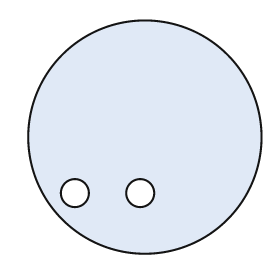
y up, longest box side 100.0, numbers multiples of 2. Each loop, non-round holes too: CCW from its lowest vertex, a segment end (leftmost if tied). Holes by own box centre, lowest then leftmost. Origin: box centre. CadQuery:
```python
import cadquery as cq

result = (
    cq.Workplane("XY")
    .moveTo(0.0, 0.0)
    .circle(50.0)
    .moveTo(-30.0, -24.0)
    .circle(6.0)
    .moveTo(-2.0, -24.0)
    .circle(6.0)
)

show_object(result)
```